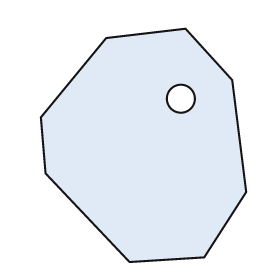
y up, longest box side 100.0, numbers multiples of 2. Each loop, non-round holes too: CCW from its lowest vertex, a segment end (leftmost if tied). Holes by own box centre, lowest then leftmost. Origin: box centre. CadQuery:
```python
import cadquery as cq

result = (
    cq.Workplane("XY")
    .moveTo(-6.0, -50.0)
    .lineTo(26.0, -48.0)
    .lineTo(44.0, -20.0)
    .lineTo(38.0, 28.0)
    .lineTo(18.0, 50.0)
    .lineTo(-16.0, 46.0)
    .lineTo(-44.0, 12.0)
    .lineTo(-42.0, -12.0)
    .close()
    .moveTo(16.0, 20.0)
    .circle(6.0)
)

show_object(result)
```